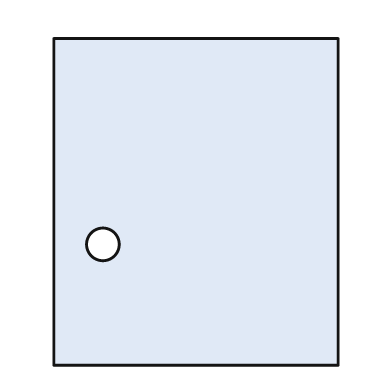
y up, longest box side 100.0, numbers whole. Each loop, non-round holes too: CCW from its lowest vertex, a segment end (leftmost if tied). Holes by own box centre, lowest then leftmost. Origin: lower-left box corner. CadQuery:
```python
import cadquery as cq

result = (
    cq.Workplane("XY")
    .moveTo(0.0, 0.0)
    .lineTo(87.0, 0.0)
    .lineTo(87.0, 100.0)
    .lineTo(0.0, 100.0)
    .close()
    .moveTo(15.0, 37.0)
    .circle(5.0)
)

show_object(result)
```